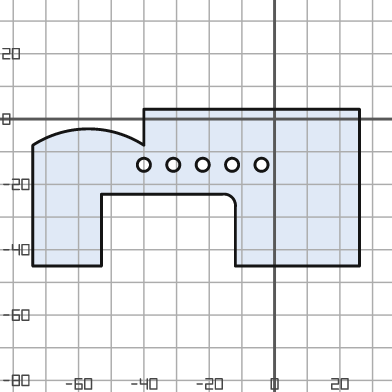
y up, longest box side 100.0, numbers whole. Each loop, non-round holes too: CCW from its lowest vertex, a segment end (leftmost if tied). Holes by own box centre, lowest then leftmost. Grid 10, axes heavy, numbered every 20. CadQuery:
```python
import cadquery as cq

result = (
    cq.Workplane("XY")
    .moveTo(-74.0, -45.0)
    .lineTo(-53.0, -45.0)
    .lineTo(-53.0, -23.0)
    .lineTo(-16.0, -23.0)
    .threePointArc((-13.0, -24.0), (-12.0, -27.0))
    .lineTo(-12.0, -45.0)
    .lineTo(26.0, -45.0)
    .lineTo(26.0, 3.0)
    .lineTo(-40.0, 3.0)
    .lineTo(-40.0, -8.0)
    .threePointArc((-57.0, -3.0), (-74.0, -8.0))
    .close()
    .moveTo(-40.0, -14.0)
    .circle(2.0)
    .moveTo(-31.0, -14.0)
    .circle(2.0)
    .moveTo(-22.0, -14.0)
    .circle(2.0)
    .moveTo(-13.0, -14.0)
    .circle(2.0)
    .moveTo(-4.0, -14.0)
    .circle(2.0)
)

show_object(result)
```